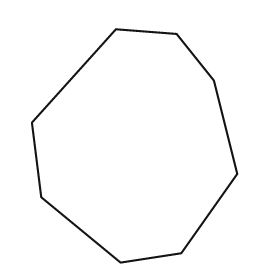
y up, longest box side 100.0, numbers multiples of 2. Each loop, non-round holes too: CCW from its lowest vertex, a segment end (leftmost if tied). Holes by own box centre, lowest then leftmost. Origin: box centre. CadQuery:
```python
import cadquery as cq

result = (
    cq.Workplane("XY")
    .moveTo(-6.0, -50.0)
    .lineTo(20.0, -46.0)
    .lineTo(44.0, -12.0)
    .lineTo(34.0, 28.0)
    .lineTo(18.0, 48.0)
    .lineTo(-8.0, 50.0)
    .lineTo(-44.0, 10.0)
    .lineTo(-40.0, -22.0)
    .close()
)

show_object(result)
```